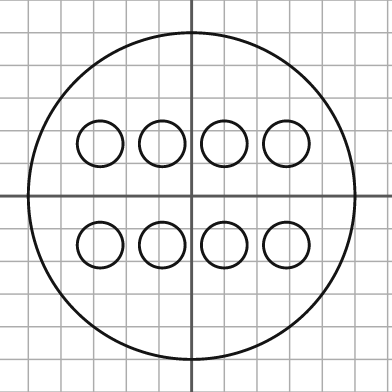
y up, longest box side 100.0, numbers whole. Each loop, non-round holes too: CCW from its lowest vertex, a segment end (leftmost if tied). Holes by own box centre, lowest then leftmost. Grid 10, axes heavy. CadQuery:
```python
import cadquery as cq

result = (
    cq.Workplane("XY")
    .moveTo(0.0, 0.0)
    .circle(50.0)
    .moveTo(-28.0, -15.0)
    .circle(7.0)
    .moveTo(-9.0, -15.0)
    .circle(7.0)
    .moveTo(10.0, -15.0)
    .circle(7.0)
    .moveTo(29.0, -15.0)
    .circle(7.0)
    .moveTo(-28.0, 16.0)
    .circle(7.0)
    .moveTo(-9.0, 16.0)
    .circle(7.0)
    .moveTo(10.0, 16.0)
    .circle(7.0)
    .moveTo(29.0, 16.0)
    .circle(7.0)
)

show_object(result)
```